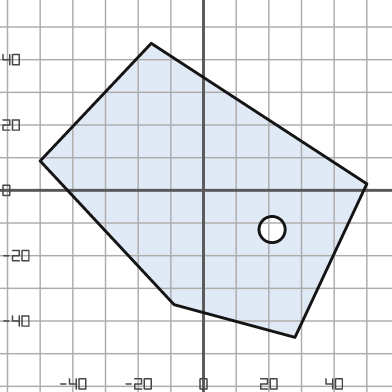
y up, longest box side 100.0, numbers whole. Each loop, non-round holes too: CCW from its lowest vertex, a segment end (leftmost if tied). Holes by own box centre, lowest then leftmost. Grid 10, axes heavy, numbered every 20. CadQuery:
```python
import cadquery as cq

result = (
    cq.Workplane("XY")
    .moveTo(28.0, -45.0)
    .lineTo(50.0, 2.0)
    .lineTo(-16.0, 45.0)
    .lineTo(-50.0, 9.0)
    .lineTo(-9.0, -35.0)
    .close()
    .moveTo(21.0, -12.0)
    .circle(4.0)
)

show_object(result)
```